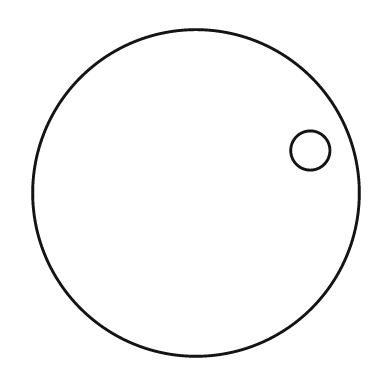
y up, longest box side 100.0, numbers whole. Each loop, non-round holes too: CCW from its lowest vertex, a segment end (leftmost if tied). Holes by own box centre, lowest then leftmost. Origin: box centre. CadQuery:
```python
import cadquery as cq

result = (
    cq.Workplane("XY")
    .moveTo(0.0, 0.0)
    .circle(50.0)
    .moveTo(35.0, 13.0)
    .circle(6.0)
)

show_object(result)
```